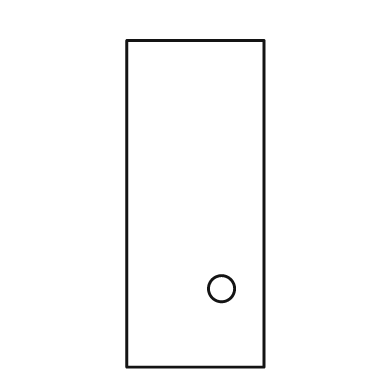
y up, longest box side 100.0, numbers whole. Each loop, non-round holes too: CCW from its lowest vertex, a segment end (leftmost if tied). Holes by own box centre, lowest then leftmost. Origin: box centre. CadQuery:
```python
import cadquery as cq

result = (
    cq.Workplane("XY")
    .moveTo(-21.0, -50.0)
    .lineTo(21.0, -50.0)
    .lineTo(21.0, 50.0)
    .lineTo(-21.0, 50.0)
    .close()
    .moveTo(8.0, -26.0)
    .circle(4.0)
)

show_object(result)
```